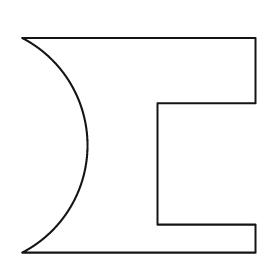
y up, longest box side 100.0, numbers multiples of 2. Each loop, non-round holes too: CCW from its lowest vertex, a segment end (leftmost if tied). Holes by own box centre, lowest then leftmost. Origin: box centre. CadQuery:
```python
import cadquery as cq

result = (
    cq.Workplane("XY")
    .moveTo(-50.0, -46.0)
    .lineTo(50.0, -46.0)
    .lineTo(50.0, -34.0)
    .lineTo(8.0, -34.0)
    .lineTo(8.0, 18.0)
    .lineTo(50.0, 18.0)
    .lineTo(50.0, 46.0)
    .lineTo(-50.0, 46.0)
    .threePointArc((-22.0, 0.0), (-50.0, -46.0))
    .close()
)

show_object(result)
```